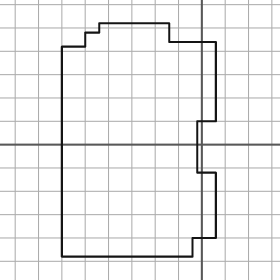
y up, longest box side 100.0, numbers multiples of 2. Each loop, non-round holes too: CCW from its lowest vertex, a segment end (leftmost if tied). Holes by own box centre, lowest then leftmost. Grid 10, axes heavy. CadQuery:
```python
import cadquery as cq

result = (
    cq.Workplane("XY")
    .moveTo(-60.0, -48.0)
    .lineTo(-4.0, -48.0)
    .lineTo(-4.0, -40.0)
    .lineTo(6.0, -40.0)
    .lineTo(6.0, -12.0)
    .lineTo(-2.0, -12.0)
    .lineTo(-2.0, 10.0)
    .lineTo(6.0, 10.0)
    .lineTo(6.0, 44.0)
    .lineTo(-14.0, 44.0)
    .lineTo(-14.0, 52.0)
    .lineTo(-44.0, 52.0)
    .lineTo(-44.0, 48.0)
    .lineTo(-50.0, 48.0)
    .lineTo(-50.0, 42.0)
    .lineTo(-60.0, 42.0)
    .close()
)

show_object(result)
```